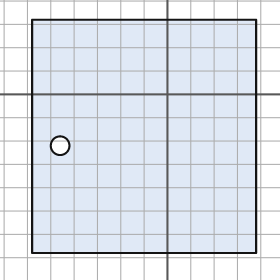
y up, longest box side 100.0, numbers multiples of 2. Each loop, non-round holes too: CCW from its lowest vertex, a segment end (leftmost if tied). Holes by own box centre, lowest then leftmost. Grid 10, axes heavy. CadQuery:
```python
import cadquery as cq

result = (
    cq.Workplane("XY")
    .moveTo(-58.0, -68.0)
    .lineTo(38.0, -68.0)
    .lineTo(38.0, 32.0)
    .lineTo(-58.0, 32.0)
    .close()
    .moveTo(-46.0, -22.0)
    .circle(4.0)
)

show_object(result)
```